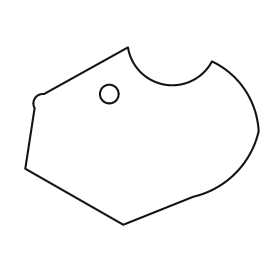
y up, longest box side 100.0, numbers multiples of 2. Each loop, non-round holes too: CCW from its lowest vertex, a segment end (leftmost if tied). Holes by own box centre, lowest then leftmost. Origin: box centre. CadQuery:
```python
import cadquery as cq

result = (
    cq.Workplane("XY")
    .moveTo(-8.0, -38.0)
    .lineTo(22.0, -26.0)
    .threePointArc((40.0, -16.0), (50.0, 2.0))
    .threePointArc((44.0, 20.0), (30.0, 32.0))
    .threePointArc((10.0, 22.0), (-6.0, 38.0))
    .lineTo(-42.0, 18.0)
    .threePointArc((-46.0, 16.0), (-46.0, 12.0))
    .lineTo(-50.0, -14.0)
    .close()
    .moveTo(-14.0, 18.0)
    .circle(4.0)
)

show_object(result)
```